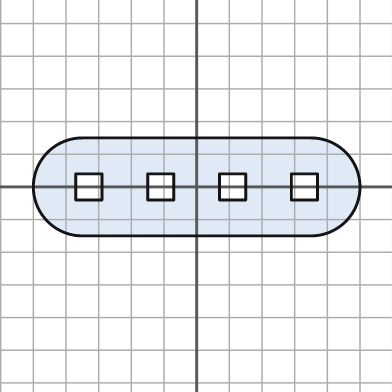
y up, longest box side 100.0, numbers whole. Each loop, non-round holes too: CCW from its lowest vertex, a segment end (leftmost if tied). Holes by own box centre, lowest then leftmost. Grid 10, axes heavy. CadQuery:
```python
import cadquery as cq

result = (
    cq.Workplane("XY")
    .moveTo(-35.0, -15.0)
    .lineTo(35.0, -15.0)
    .threePointArc((50.0, 0.0), (35.0, 15.0))
    .lineTo(-35.0, 15.0)
    .threePointArc((-50.0, 0.0), (-35.0, -15.0))
    .close()
    .moveTo(-37.0, -4.0)
    .lineTo(-29.0, -4.0)
    .lineTo(-29.0, 4.0)
    .lineTo(-37.0, 4.0)
    .close()
    .moveTo(-15.0, -4.0)
    .lineTo(-7.0, -4.0)
    .lineTo(-7.0, 4.0)
    .lineTo(-15.0, 4.0)
    .close()
    .moveTo(7.0, -4.0)
    .lineTo(15.0, -4.0)
    .lineTo(15.0, 4.0)
    .lineTo(7.0, 4.0)
    .close()
    .moveTo(29.0, -4.0)
    .lineTo(37.0, -4.0)
    .lineTo(37.0, 4.0)
    .lineTo(29.0, 4.0)
    .close()
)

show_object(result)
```